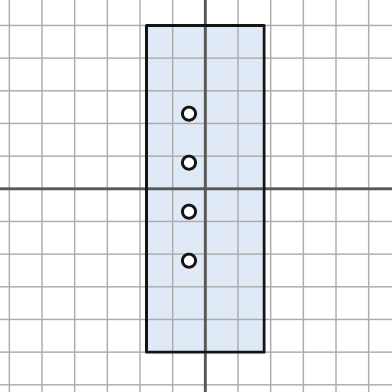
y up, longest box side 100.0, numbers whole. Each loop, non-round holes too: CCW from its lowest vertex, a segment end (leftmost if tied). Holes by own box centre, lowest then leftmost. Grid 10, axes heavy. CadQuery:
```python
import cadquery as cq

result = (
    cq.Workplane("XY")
    .moveTo(-18.0, -50.0)
    .lineTo(18.0, -50.0)
    .lineTo(18.0, 50.0)
    .lineTo(-18.0, 50.0)
    .close()
    .moveTo(-5.0, -22.0)
    .circle(2.0)
    .moveTo(-5.0, -7.0)
    .circle(2.0)
    .moveTo(-5.0, 8.0)
    .circle(2.0)
    .moveTo(-5.0, 23.0)
    .circle(2.0)
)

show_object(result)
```